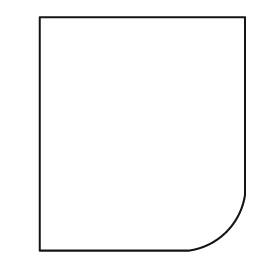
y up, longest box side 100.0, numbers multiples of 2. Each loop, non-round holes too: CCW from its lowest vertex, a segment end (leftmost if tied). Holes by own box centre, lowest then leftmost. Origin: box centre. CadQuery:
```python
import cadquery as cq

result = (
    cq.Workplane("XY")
    .moveTo(-44.0, -50.0)
    .lineTo(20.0, -50.0)
    .threePointArc((36.0, -42.0), (44.0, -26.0))
    .lineTo(44.0, 50.0)
    .lineTo(-44.0, 50.0)
    .close()
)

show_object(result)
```